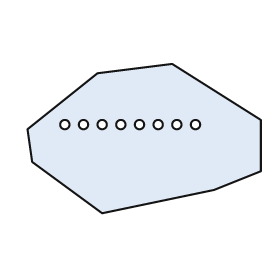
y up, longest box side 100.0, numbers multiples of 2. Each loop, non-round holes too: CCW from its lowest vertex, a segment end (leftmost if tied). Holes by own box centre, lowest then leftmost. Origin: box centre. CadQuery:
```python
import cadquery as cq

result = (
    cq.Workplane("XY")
    .moveTo(-18.0, -32.0)
    .lineTo(30.0, -22.0)
    .lineTo(50.0, -14.0)
    .lineTo(50.0, 8.0)
    .lineTo(12.0, 32.0)
    .lineTo(-20.0, 28.0)
    .lineTo(-50.0, 4.0)
    .lineTo(-48.0, -10.0)
    .close()
    .moveTo(-34.0, 6.0)
    .circle(2.0)
    .moveTo(-26.0, 6.0)
    .circle(2.0)
    .moveTo(-18.0, 6.0)
    .circle(2.0)
    .moveTo(-10.0, 6.0)
    .circle(2.0)
    .moveTo(-2.0, 6.0)
    .circle(2.0)
    .moveTo(6.0, 6.0)
    .circle(2.0)
    .moveTo(14.0, 6.0)
    .circle(2.0)
    .moveTo(22.0, 6.0)
    .circle(2.0)
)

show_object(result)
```